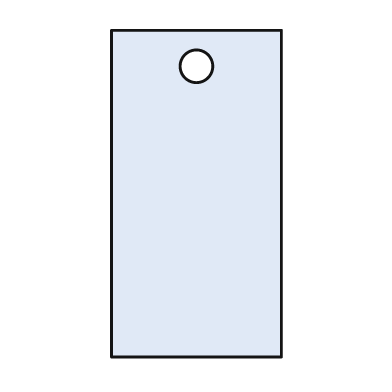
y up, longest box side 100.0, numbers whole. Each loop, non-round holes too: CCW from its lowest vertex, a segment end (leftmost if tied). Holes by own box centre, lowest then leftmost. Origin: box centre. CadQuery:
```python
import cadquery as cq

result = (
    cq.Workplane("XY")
    .moveTo(-26.0, -50.0)
    .lineTo(26.0, -50.0)
    .lineTo(26.0, 50.0)
    .lineTo(-26.0, 50.0)
    .close()
    .moveTo(0.0, 39.0)
    .circle(5.0)
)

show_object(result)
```